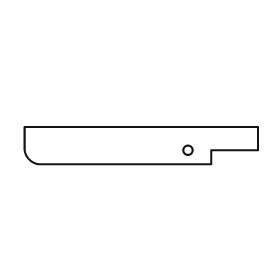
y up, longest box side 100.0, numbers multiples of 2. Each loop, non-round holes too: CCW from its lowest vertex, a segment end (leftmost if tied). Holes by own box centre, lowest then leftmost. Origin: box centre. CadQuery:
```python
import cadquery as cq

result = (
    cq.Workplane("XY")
    .moveTo(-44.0, -8.0)
    .lineTo(30.0, -8.0)
    .lineTo(30.0, -2.0)
    .lineTo(50.0, -2.0)
    .lineTo(50.0, 8.0)
    .lineTo(-50.0, 8.0)
    .lineTo(-50.0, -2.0)
    .threePointArc((-48.0, -6.0), (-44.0, -8.0))
    .close()
    .moveTo(20.0, -2.0)
    .circle(2.0)
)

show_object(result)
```